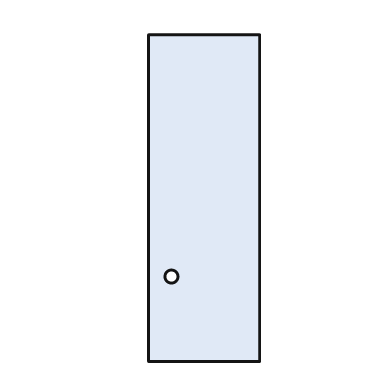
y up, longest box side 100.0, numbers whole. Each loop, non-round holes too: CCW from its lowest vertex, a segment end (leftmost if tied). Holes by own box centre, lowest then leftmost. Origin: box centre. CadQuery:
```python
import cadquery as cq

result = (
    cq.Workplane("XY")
    .moveTo(-17.0, -50.0)
    .lineTo(17.0, -50.0)
    .lineTo(17.0, 50.0)
    .lineTo(-17.0, 50.0)
    .close()
    .moveTo(-10.0, -24.0)
    .circle(2.0)
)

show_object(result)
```